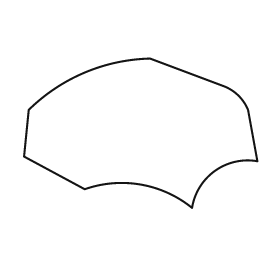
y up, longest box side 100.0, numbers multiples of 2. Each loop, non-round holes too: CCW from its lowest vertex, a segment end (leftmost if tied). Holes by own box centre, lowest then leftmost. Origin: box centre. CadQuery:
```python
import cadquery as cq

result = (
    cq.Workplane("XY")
    .moveTo(22.0, -32.0)
    .threePointArc((32.0, -16.0), (50.0, -12.0))
    .lineTo(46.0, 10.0)
    .threePointArc((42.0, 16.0), (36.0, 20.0))
    .lineTo(4.0, 32.0)
    .threePointArc((-24.0, 26.0), (-48.0, 10.0))
    .lineTo(-50.0, -10.0)
    .lineTo(-24.0, -24.0)
    .threePointArc((0.0, -22.0), (22.0, -32.0))
    .close()
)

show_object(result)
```